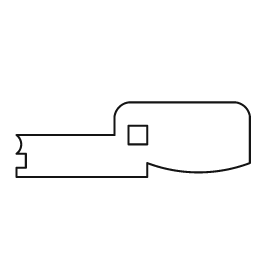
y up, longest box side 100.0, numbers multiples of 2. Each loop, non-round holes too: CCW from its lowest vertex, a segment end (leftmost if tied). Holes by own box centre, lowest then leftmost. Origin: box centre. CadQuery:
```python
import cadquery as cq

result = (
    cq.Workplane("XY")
    .moveTo(-50.0, -16.0)
    .lineTo(6.0, -16.0)
    .lineTo(6.0, -10.0)
    .threePointArc((28.0, -14.0), (50.0, -10.0))
    .lineTo(50.0, 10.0)
    .threePointArc((48.0, 14.0), (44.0, 16.0))
    .lineTo(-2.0, 16.0)
    .threePointArc((-6.0, 14.0), (-8.0, 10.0))
    .lineTo(-8.0, 2.0)
    .lineTo(-50.0, 2.0)
    .threePointArc((-48.0, -2.0), (-50.0, -6.0))
    .lineTo(-46.0, -6.0)
    .lineTo(-46.0, -12.0)
    .lineTo(-50.0, -12.0)
    .close()
    .moveTo(-2.0, -2.0)
    .lineTo(6.0, -2.0)
    .lineTo(6.0, 6.0)
    .lineTo(-2.0, 6.0)
    .close()
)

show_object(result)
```